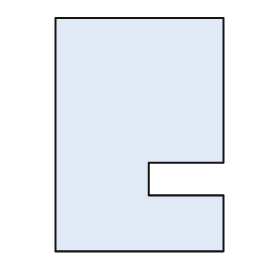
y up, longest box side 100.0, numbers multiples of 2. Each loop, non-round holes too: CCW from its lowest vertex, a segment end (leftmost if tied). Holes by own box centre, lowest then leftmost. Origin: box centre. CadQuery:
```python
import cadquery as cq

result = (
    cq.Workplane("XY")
    .moveTo(-36.0, -50.0)
    .lineTo(36.0, -50.0)
    .lineTo(36.0, -26.0)
    .lineTo(4.0, -26.0)
    .lineTo(4.0, -12.0)
    .lineTo(36.0, -12.0)
    .lineTo(36.0, 50.0)
    .lineTo(-36.0, 50.0)
    .close()
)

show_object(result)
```